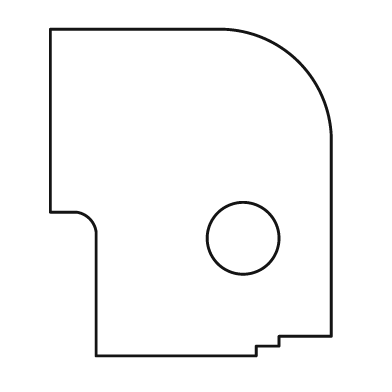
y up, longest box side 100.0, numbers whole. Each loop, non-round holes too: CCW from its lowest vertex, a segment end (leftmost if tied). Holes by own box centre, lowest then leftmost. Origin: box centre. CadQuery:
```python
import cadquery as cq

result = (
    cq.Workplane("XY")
    .moveTo(-29.0, -50.0)
    .lineTo(20.0, -50.0)
    .lineTo(20.0, -47.0)
    .lineTo(27.0, -47.0)
    .lineTo(27.0, -44.0)
    .lineTo(43.0, -44.0)
    .lineTo(43.0, 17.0)
    .threePointArc((33.0, 40.0), (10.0, 50.0))
    .lineTo(-43.0, 50.0)
    .lineTo(-43.0, -6.0)
    .lineTo(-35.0, -6.0)
    .threePointArc((-31.0, -8.0), (-29.0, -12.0))
    .close()
    .moveTo(16.0, -14.0)
    .circle(11.0)
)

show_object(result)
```